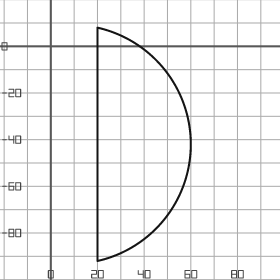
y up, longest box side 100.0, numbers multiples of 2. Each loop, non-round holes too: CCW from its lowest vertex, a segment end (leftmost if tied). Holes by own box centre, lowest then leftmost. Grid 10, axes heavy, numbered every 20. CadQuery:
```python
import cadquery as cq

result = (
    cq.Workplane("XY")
    .moveTo(20.0, -92.0)
    .threePointArc((60.0, -42.0), (20.0, 8.0))
    .close()
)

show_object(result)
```